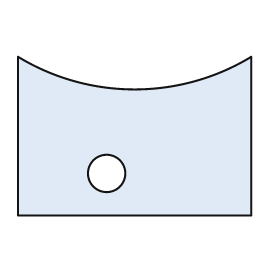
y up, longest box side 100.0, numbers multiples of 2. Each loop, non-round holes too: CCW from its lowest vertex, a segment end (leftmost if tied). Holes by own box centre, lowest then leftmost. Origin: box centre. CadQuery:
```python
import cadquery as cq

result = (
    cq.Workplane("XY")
    .moveTo(-50.0, -34.0)
    .lineTo(50.0, -34.0)
    .lineTo(50.0, 34.0)
    .threePointArc((0.0, 20.0), (-50.0, 34.0))
    .close()
    .moveTo(-12.0, -16.0)
    .circle(8.0)
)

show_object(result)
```